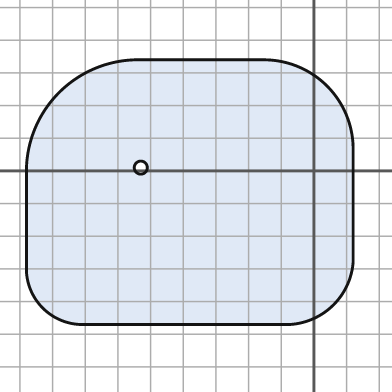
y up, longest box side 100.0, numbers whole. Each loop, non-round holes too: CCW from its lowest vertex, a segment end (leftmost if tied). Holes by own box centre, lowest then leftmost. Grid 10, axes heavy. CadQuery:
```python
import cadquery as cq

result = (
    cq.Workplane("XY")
    .moveTo(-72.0, -47.0)
    .lineTo(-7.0, -47.0)
    .threePointArc((6.0, -41.0), (12.0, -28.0))
    .lineTo(12.0, 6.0)
    .threePointArc((4.0, 26.0), (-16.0, 34.0))
    .lineTo(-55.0, 34.0)
    .threePointArc((-78.0, 24.0), (-88.0, 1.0))
    .lineTo(-88.0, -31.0)
    .threePointArc((-83.0, -42.0), (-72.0, -47.0))
    .close()
    .moveTo(-53.0, 1.0)
    .circle(2.0)
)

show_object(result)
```